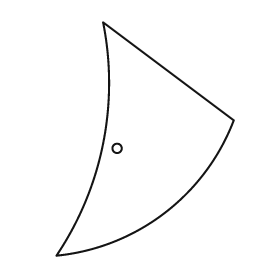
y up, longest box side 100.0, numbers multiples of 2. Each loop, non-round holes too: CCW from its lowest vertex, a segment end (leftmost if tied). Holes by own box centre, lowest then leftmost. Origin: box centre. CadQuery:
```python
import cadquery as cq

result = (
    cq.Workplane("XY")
    .moveTo(-38.0, -50.0)
    .threePointArc((8.0, -32.0), (38.0, 8.0))
    .lineTo(-18.0, 50.0)
    .threePointArc((-18.0, -2.0), (-38.0, -50.0))
    .close()
    .moveTo(-12.0, -4.0)
    .circle(2.0)
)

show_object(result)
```